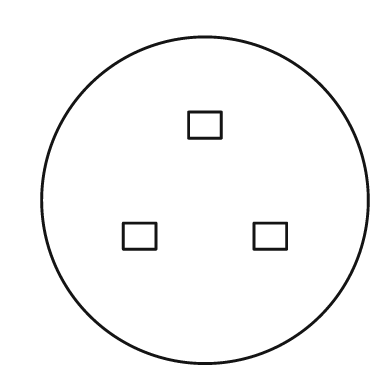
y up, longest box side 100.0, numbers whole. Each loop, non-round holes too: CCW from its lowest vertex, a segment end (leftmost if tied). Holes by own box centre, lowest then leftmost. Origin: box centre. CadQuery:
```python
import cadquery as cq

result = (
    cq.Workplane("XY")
    .moveTo(0.0, 0.0)
    .circle(50.0)
    .moveTo(-25.0, -15.0)
    .lineTo(-15.0, -15.0)
    .lineTo(-15.0, -7.0)
    .lineTo(-25.0, -7.0)
    .close()
    .moveTo(15.0, -15.0)
    .lineTo(25.0, -15.0)
    .lineTo(25.0, -7.0)
    .lineTo(15.0, -7.0)
    .close()
    .moveTo(-5.0, 19.0)
    .lineTo(5.0, 19.0)
    .lineTo(5.0, 27.0)
    .lineTo(-5.0, 27.0)
    .close()
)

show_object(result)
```